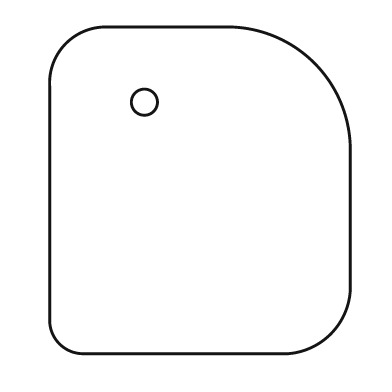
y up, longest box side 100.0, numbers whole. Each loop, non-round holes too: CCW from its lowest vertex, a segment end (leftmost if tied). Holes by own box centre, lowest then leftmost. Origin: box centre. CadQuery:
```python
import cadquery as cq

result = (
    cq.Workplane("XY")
    .moveTo(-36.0, -50.0)
    .lineTo(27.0, -50.0)
    .threePointArc((40.0, -44.0), (46.0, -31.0))
    .lineTo(46.0, 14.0)
    .threePointArc((35.0, 39.0), (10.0, 50.0))
    .lineTo(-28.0, 50.0)
    .threePointArc((-41.0, 45.0), (-46.0, 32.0))
    .lineTo(-46.0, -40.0)
    .threePointArc((-43.0, -47.0), (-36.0, -50.0))
    .close()
    .moveTo(-17.0, 27.0)
    .circle(4.0)
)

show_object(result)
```